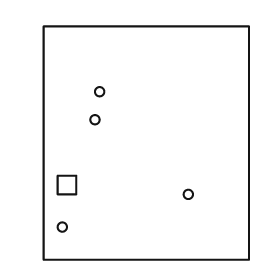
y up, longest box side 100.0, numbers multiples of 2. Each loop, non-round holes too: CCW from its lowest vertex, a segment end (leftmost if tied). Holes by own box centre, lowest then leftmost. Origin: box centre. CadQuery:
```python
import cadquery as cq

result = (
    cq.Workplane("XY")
    .moveTo(-44.0, -50.0)
    .lineTo(44.0, -50.0)
    .lineTo(44.0, 50.0)
    .lineTo(-44.0, 50.0)
    .close()
    .moveTo(-36.0, -36.0)
    .circle(2.0)
    .moveTo(18.0, -22.0)
    .circle(2.0)
    .moveTo(-38.0, -22.0)
    .lineTo(-30.0, -22.0)
    .lineTo(-30.0, -14.0)
    .lineTo(-38.0, -14.0)
    .close()
    .moveTo(-22.0, 10.0)
    .circle(2.0)
    .moveTo(-20.0, 22.0)
    .circle(2.0)
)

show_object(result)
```